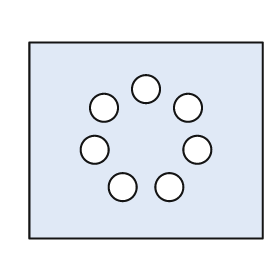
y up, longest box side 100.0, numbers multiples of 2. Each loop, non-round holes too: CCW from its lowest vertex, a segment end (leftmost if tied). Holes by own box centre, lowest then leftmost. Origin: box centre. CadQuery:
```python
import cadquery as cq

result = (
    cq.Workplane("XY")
    .moveTo(-50.0, -42.0)
    .lineTo(50.0, -42.0)
    .lineTo(50.0, 42.0)
    .lineTo(-50.0, 42.0)
    .close()
    .moveTo(-10.0, -20.0)
    .circle(6.0)
    .moveTo(10.0, -20.0)
    .circle(6.0)
    .moveTo(-22.0, -4.0)
    .circle(6.0)
    .moveTo(22.0, -4.0)
    .circle(6.0)
    .moveTo(-18.0, 14.0)
    .circle(6.0)
    .moveTo(18.0, 14.0)
    .circle(6.0)
    .moveTo(0.0, 22.0)
    .circle(6.0)
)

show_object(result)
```